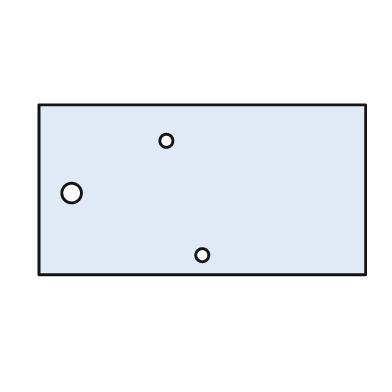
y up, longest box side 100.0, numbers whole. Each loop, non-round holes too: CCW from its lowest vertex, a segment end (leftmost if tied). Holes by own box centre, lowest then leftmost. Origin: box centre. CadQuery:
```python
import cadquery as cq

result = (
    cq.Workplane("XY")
    .moveTo(-50.0, -26.0)
    .lineTo(50.0, -26.0)
    .lineTo(50.0, 26.0)
    .lineTo(-50.0, 26.0)
    .close()
    .moveTo(0.0, -20.0)
    .circle(2.0)
    .moveTo(-40.0, -1.0)
    .circle(3.0)
    .moveTo(-11.0, 15.0)
    .circle(2.0)
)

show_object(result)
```